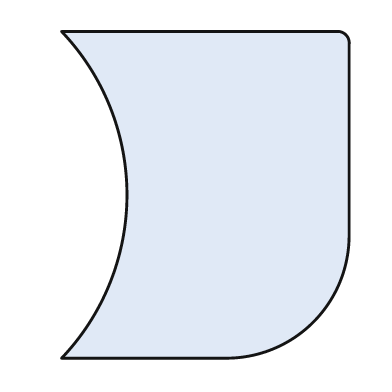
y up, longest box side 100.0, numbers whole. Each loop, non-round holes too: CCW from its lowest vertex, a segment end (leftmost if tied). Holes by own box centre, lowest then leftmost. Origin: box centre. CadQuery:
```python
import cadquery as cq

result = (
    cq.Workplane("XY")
    .moveTo(-44.0, -50.0)
    .lineTo(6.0, -50.0)
    .threePointArc((33.0, -39.0), (44.0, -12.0))
    .lineTo(44.0, 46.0)
    .threePointArc((43.0, 49.0), (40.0, 50.0))
    .lineTo(-44.0, 50.0)
    .threePointArc((-24.0, 0.0), (-44.0, -50.0))
    .close()
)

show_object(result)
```